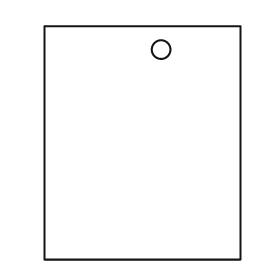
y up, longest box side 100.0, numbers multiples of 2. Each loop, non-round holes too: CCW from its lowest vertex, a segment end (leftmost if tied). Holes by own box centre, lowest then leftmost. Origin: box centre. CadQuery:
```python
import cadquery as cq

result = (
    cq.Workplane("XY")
    .moveTo(-42.0, -50.0)
    .lineTo(42.0, -50.0)
    .lineTo(42.0, 50.0)
    .lineTo(-42.0, 50.0)
    .close()
    .moveTo(8.0, 40.0)
    .circle(4.0)
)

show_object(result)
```